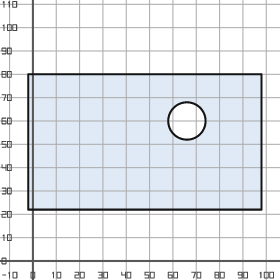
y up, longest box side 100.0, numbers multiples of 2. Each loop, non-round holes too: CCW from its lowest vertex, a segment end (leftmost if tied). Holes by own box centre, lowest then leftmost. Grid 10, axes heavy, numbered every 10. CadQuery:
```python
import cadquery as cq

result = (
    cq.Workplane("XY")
    .moveTo(-2.0, 22.0)
    .lineTo(98.0, 22.0)
    .lineTo(98.0, 80.0)
    .lineTo(-2.0, 80.0)
    .close()
    .moveTo(66.0, 60.0)
    .circle(8.0)
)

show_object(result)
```